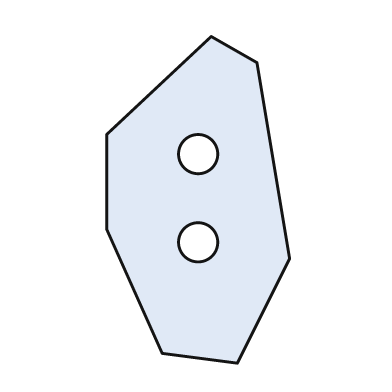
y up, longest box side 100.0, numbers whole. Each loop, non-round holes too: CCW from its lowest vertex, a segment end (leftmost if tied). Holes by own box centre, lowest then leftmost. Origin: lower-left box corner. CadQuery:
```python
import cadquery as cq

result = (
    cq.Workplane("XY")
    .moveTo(40.0, 0.0)
    .lineTo(56.0, 32.0)
    .lineTo(46.0, 92.0)
    .lineTo(32.0, 100.0)
    .lineTo(0.0, 70.0)
    .lineTo(0.0, 41.0)
    .lineTo(17.0, 3.0)
    .close()
    .moveTo(28.0, 37.0)
    .circle(6.0)
    .moveTo(28.0, 64.0)
    .circle(6.0)
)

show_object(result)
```